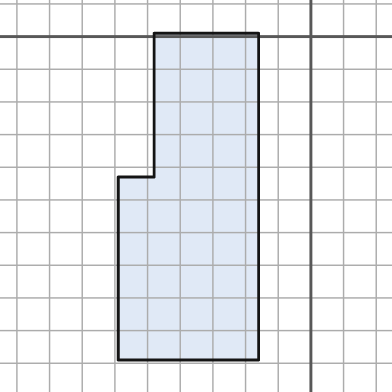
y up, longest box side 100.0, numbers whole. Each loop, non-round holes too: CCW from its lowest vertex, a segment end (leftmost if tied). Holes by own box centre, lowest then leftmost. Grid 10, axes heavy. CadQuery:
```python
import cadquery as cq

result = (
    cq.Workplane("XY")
    .moveTo(-59.0, -99.0)
    .lineTo(-16.0, -99.0)
    .lineTo(-16.0, 1.0)
    .lineTo(-48.0, 1.0)
    .lineTo(-48.0, -43.0)
    .lineTo(-59.0, -43.0)
    .close()
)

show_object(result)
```